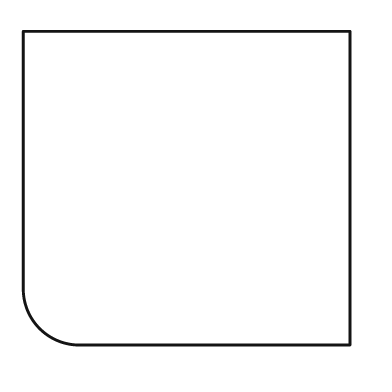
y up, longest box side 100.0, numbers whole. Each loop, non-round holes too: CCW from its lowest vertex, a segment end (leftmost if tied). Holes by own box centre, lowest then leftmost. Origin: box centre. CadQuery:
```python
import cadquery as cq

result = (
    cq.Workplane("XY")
    .moveTo(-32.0, -48.0)
    .lineTo(50.0, -48.0)
    .lineTo(50.0, 48.0)
    .lineTo(-50.0, 48.0)
    .lineTo(-50.0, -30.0)
    .threePointArc((-45.0, -43.0), (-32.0, -48.0))
    .close()
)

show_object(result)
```